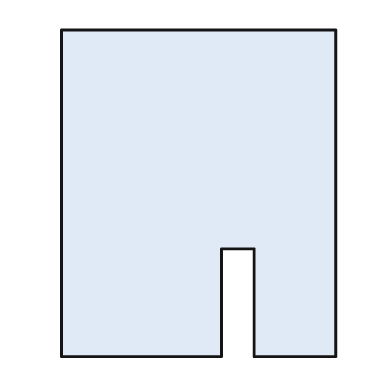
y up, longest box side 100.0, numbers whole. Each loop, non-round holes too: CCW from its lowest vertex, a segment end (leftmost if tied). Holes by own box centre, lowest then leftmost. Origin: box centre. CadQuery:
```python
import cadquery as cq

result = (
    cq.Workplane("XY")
    .moveTo(-42.0, -50.0)
    .lineTo(7.0, -50.0)
    .lineTo(7.0, -17.0)
    .lineTo(17.0, -17.0)
    .lineTo(17.0, -50.0)
    .lineTo(42.0, -50.0)
    .lineTo(42.0, 50.0)
    .lineTo(-42.0, 50.0)
    .close()
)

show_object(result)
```